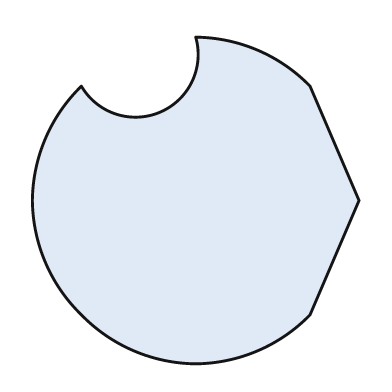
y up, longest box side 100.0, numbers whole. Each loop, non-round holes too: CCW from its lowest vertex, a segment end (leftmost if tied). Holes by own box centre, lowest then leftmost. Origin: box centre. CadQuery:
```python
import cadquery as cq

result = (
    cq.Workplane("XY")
    .moveTo(0.0, -50.0)
    .threePointArc((19.0, -46.0), (35.0, -35.0))
    .lineTo(50.0, 0.0)
    .lineTo(35.0, 35.0)
    .threePointArc((19.0, 46.0), (0.0, 50.0))
    .threePointArc((-11.0, 27.0), (-35.0, 35.0))
    .threePointArc((-46.0, 19.0), (-50.0, 0.0))
    .threePointArc((-46.0, -19.0), (-35.0, -35.0))
    .threePointArc((-19.0, -46.0), (0.0, -50.0))
    .close()
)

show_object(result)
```